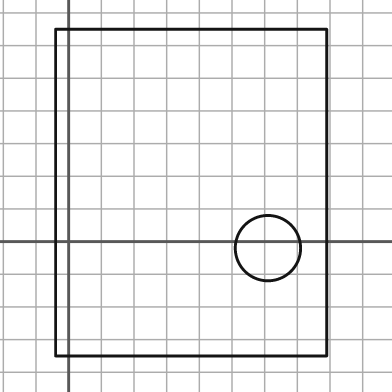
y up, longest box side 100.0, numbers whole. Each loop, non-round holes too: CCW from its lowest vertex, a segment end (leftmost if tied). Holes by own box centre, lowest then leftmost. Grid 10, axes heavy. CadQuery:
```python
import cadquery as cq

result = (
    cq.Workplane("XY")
    .moveTo(-4.0, -35.0)
    .lineTo(79.0, -35.0)
    .lineTo(79.0, 65.0)
    .lineTo(-4.0, 65.0)
    .close()
    .moveTo(61.0, -2.0)
    .circle(10.0)
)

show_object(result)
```